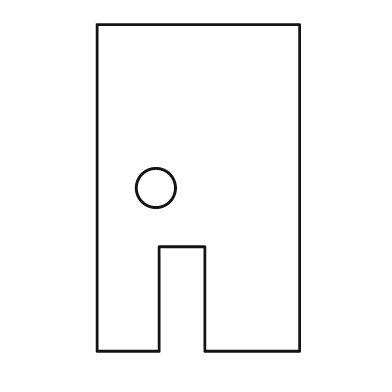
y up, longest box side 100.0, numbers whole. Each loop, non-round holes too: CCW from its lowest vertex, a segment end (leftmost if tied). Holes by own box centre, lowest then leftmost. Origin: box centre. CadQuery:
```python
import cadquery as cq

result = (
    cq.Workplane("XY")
    .moveTo(-31.0, -50.0)
    .lineTo(-12.0, -50.0)
    .lineTo(-12.0, -18.0)
    .lineTo(2.0, -18.0)
    .lineTo(2.0, -50.0)
    .lineTo(31.0, -50.0)
    .lineTo(31.0, 50.0)
    .lineTo(-31.0, 50.0)
    .close()
    .moveTo(-13.0, 0.0)
    .circle(6.0)
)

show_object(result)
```